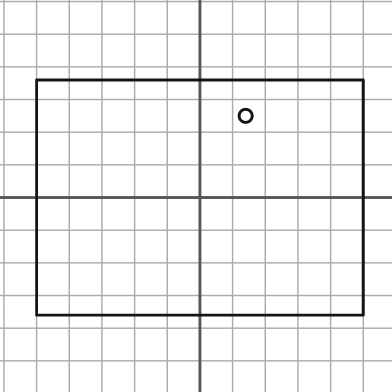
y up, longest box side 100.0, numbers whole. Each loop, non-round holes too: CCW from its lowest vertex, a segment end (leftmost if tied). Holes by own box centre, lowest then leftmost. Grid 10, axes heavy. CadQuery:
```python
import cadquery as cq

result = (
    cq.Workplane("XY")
    .moveTo(-50.0, -36.0)
    .lineTo(50.0, -36.0)
    .lineTo(50.0, 36.0)
    .lineTo(-50.0, 36.0)
    .close()
    .moveTo(14.0, 25.0)
    .circle(2.0)
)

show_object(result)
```